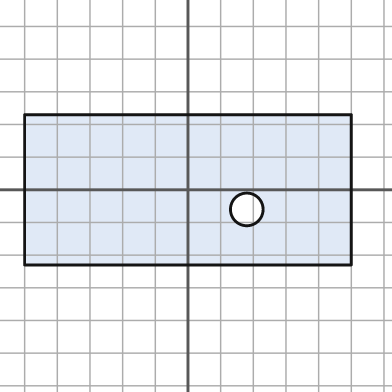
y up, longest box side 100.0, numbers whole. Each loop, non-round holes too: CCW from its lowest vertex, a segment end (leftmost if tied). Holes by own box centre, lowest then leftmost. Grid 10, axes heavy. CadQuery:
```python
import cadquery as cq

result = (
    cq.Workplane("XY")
    .moveTo(-50.0, -23.0)
    .lineTo(50.0, -23.0)
    .lineTo(50.0, 23.0)
    .lineTo(-50.0, 23.0)
    .close()
    .moveTo(18.0, -6.0)
    .circle(5.0)
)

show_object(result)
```